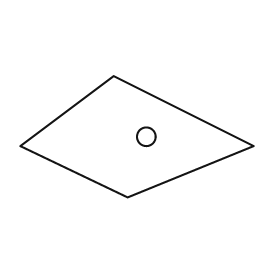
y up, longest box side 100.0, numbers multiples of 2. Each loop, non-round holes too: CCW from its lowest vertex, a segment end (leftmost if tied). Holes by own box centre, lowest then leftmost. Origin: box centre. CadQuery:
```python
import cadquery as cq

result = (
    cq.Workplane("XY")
    .moveTo(-4.0, -26.0)
    .lineTo(50.0, -4.0)
    .lineTo(-10.0, 26.0)
    .lineTo(-50.0, -4.0)
    .close()
    .moveTo(4.0, 0.0)
    .circle(4.0)
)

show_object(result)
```